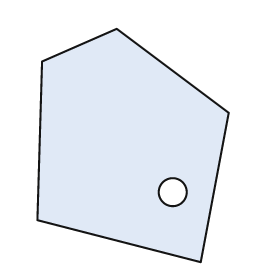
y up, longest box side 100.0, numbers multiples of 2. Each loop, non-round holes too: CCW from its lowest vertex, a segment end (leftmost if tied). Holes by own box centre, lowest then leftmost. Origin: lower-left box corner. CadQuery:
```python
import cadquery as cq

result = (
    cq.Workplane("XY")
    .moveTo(70.0, 0.0)
    .lineTo(82.0, 64.0)
    .lineTo(34.0, 100.0)
    .lineTo(2.0, 86.0)
    .lineTo(0.0, 18.0)
    .close()
    .moveTo(58.0, 30.0)
    .circle(6.0)
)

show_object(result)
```